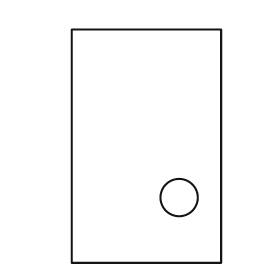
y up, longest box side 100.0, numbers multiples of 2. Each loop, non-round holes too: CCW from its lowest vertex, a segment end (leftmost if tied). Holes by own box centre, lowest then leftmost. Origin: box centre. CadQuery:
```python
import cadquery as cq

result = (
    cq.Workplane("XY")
    .moveTo(-32.0, -50.0)
    .lineTo(32.0, -50.0)
    .lineTo(32.0, 50.0)
    .lineTo(-32.0, 50.0)
    .close()
    .moveTo(14.0, -22.0)
    .circle(8.0)
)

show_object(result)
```